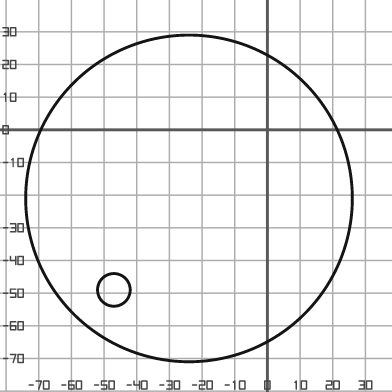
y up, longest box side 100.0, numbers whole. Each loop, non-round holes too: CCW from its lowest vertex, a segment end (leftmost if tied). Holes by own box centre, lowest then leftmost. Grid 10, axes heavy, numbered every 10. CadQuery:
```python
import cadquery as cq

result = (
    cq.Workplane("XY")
    .moveTo(-24.0, -21.0)
    .circle(50.0)
    .moveTo(-47.0, -49.0)
    .circle(5.0)
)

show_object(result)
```